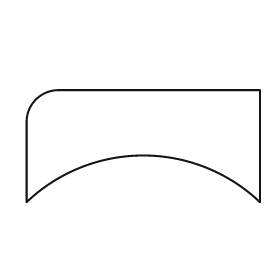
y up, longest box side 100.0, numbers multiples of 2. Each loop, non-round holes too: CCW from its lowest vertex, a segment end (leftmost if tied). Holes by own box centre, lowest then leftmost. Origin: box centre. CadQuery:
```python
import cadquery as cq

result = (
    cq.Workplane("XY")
    .moveTo(-50.0, -24.0)
    .threePointArc((0.0, -4.0), (50.0, -24.0))
    .lineTo(50.0, 24.0)
    .lineTo(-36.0, 24.0)
    .threePointArc((-46.0, 20.0), (-50.0, 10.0))
    .close()
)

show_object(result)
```